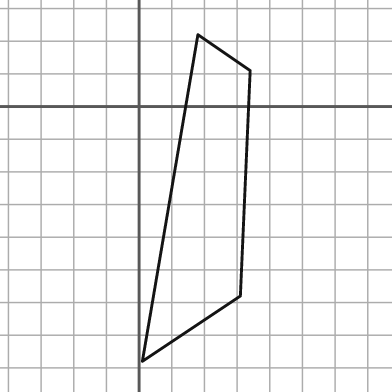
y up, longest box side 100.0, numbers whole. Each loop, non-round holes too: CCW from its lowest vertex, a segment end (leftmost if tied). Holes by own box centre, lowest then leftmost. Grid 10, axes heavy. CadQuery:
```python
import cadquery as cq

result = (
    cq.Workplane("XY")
    .moveTo(1.0, -78.0)
    .lineTo(31.0, -58.0)
    .lineTo(34.0, 11.0)
    .lineTo(18.0, 22.0)
    .close()
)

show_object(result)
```